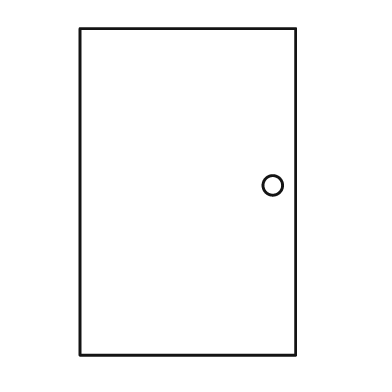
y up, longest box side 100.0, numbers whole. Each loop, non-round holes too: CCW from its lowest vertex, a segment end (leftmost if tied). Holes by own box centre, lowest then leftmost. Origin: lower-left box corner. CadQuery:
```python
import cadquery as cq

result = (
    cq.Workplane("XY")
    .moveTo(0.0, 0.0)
    .lineTo(66.0, 0.0)
    .lineTo(66.0, 100.0)
    .lineTo(0.0, 100.0)
    .close()
    .moveTo(59.0, 52.0)
    .circle(3.0)
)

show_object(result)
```